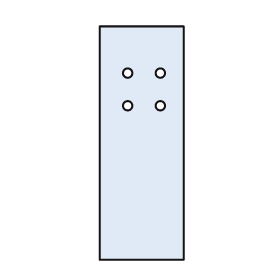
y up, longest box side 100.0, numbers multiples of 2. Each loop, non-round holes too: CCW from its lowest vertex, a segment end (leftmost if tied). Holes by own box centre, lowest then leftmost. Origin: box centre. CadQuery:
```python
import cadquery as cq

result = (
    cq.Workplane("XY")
    .moveTo(-18.0, -50.0)
    .lineTo(18.0, -50.0)
    .lineTo(18.0, 50.0)
    .lineTo(-18.0, 50.0)
    .close()
    .moveTo(-6.0, 16.0)
    .circle(2.0)
    .moveTo(8.0, 16.0)
    .circle(2.0)
    .moveTo(-6.0, 30.0)
    .circle(2.0)
    .moveTo(8.0, 30.0)
    .circle(2.0)
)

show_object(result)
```